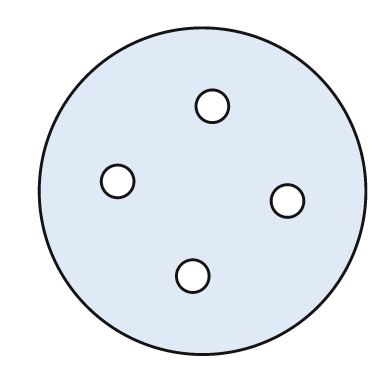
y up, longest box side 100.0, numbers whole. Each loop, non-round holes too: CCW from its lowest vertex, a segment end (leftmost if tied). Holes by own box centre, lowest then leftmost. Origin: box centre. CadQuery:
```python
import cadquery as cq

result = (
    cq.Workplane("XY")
    .moveTo(0.0, 0.0)
    .circle(50.0)
    .moveTo(-3.0, -26.0)
    .circle(5.0)
    .moveTo(26.0, -3.0)
    .circle(5.0)
    .moveTo(-26.0, 3.0)
    .circle(5.0)
    .moveTo(3.0, 26.0)
    .circle(5.0)
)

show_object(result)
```